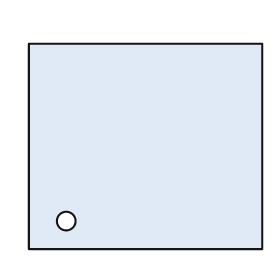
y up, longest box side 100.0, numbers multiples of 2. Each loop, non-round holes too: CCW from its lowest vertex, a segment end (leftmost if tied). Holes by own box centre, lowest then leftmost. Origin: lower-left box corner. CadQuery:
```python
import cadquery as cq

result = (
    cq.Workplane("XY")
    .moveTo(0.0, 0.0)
    .lineTo(100.0, 0.0)
    .lineTo(100.0, 88.0)
    .lineTo(0.0, 88.0)
    .close()
    .moveTo(16.0, 12.0)
    .circle(4.0)
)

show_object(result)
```